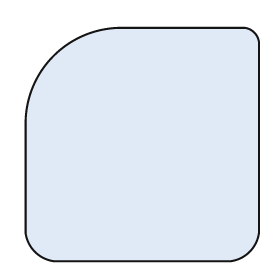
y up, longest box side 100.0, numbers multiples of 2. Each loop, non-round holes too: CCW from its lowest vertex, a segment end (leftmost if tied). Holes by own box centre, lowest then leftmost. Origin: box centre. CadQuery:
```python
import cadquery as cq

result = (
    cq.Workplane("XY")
    .moveTo(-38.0, -50.0)
    .lineTo(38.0, -50.0)
    .threePointArc((46.0, -46.0), (50.0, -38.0))
    .lineTo(50.0, 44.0)
    .threePointArc((48.0, 48.0), (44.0, 50.0))
    .lineTo(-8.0, 50.0)
    .threePointArc((-38.0, 38.0), (-50.0, 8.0))
    .lineTo(-50.0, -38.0)
    .threePointArc((-46.0, -46.0), (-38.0, -50.0))
    .close()
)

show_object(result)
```